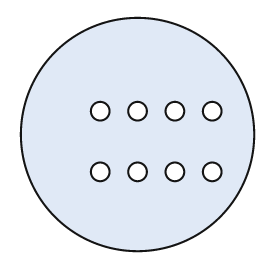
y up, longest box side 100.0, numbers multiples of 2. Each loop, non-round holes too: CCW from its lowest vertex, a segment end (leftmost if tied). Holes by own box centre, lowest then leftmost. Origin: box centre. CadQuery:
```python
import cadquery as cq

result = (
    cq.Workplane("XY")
    .moveTo(0.0, 0.0)
    .circle(50.0)
    .moveTo(-16.0, -16.0)
    .circle(4.0)
    .moveTo(0.0, -16.0)
    .circle(4.0)
    .moveTo(16.0, -16.0)
    .circle(4.0)
    .moveTo(32.0, -16.0)
    .circle(4.0)
    .moveTo(-16.0, 10.0)
    .circle(4.0)
    .moveTo(0.0, 10.0)
    .circle(4.0)
    .moveTo(16.0, 10.0)
    .circle(4.0)
    .moveTo(32.0, 10.0)
    .circle(4.0)
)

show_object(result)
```